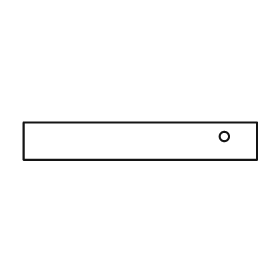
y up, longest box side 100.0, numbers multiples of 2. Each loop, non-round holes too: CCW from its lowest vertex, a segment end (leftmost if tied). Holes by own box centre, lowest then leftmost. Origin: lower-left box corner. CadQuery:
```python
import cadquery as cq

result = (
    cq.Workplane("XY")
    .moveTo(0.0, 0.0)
    .lineTo(100.0, 0.0)
    .lineTo(100.0, 16.0)
    .lineTo(0.0, 16.0)
    .close()
    .moveTo(86.0, 10.0)
    .circle(2.0)
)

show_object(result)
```